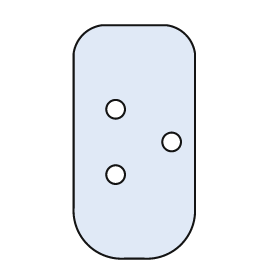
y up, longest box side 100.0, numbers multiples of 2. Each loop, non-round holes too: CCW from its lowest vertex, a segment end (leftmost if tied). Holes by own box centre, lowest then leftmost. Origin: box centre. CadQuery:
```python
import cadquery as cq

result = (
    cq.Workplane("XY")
    .moveTo(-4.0, -50.0)
    .lineTo(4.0, -50.0)
    .threePointArc((20.0, -44.0), (26.0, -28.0))
    .lineTo(26.0, 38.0)
    .threePointArc((22.0, 46.0), (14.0, 50.0))
    .lineTo(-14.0, 50.0)
    .threePointArc((-22.0, 46.0), (-26.0, 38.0))
    .lineTo(-26.0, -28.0)
    .threePointArc((-20.0, -44.0), (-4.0, -50.0))
    .close()
    .moveTo(-8.0, -14.0)
    .circle(4.0)
    .moveTo(16.0, 0.0)
    .circle(4.0)
    .moveTo(-8.0, 14.0)
    .circle(4.0)
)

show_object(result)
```